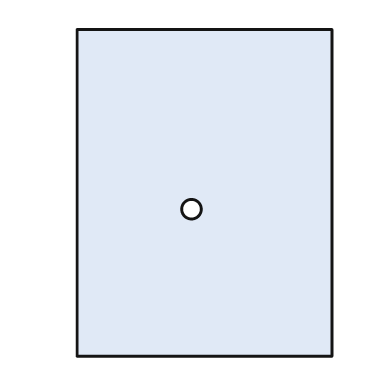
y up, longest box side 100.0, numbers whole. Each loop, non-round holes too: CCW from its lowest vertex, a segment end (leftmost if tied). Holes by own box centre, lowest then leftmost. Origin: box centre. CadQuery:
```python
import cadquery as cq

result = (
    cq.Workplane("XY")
    .moveTo(-39.0, -50.0)
    .lineTo(39.0, -50.0)
    .lineTo(39.0, 50.0)
    .lineTo(-39.0, 50.0)
    .close()
    .moveTo(-4.0, -5.0)
    .circle(3.0)
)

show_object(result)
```